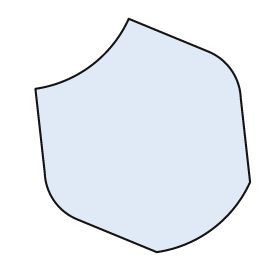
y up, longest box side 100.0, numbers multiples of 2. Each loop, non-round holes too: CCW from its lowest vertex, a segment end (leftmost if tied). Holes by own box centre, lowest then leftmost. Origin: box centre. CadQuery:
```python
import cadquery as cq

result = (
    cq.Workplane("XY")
    .moveTo(6.0, -50.0)
    .threePointArc((30.0, -40.0), (46.0, -20.0))
    .lineTo(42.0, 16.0)
    .threePointArc((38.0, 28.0), (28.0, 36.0))
    .lineTo(-6.0, 50.0)
    .threePointArc((-22.0, 30.0), (-46.0, 20.0))
    .lineTo(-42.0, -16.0)
    .threePointArc((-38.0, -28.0), (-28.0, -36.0))
    .close()
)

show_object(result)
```